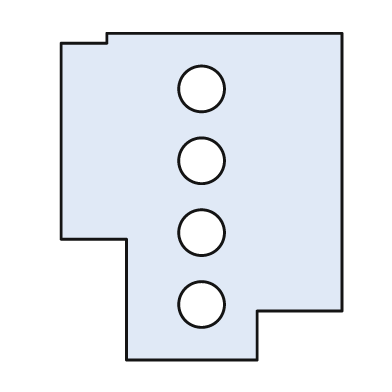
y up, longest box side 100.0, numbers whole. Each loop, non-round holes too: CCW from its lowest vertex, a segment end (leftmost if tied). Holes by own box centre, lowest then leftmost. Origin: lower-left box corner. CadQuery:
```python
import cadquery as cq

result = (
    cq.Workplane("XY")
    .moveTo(20.0, 0.0)
    .lineTo(60.0, 0.0)
    .lineTo(60.0, 15.0)
    .lineTo(86.0, 15.0)
    .lineTo(86.0, 100.0)
    .lineTo(14.0, 100.0)
    .lineTo(14.0, 97.0)
    .lineTo(0.0, 97.0)
    .lineTo(0.0, 37.0)
    .lineTo(20.0, 37.0)
    .close()
    .moveTo(43.0, 17.0)
    .circle(7.0)
    .moveTo(43.0, 39.0)
    .circle(7.0)
    .moveTo(43.0, 61.0)
    .circle(7.0)
    .moveTo(43.0, 83.0)
    .circle(7.0)
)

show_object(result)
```